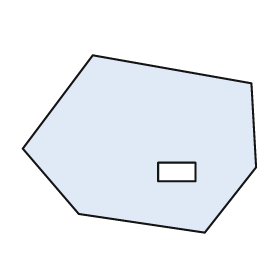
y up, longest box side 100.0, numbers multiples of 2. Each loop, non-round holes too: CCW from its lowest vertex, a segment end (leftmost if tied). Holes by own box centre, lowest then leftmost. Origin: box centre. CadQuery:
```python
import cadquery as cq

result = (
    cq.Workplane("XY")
    .moveTo(28.0, -38.0)
    .lineTo(50.0, -10.0)
    .lineTo(48.0, 26.0)
    .lineTo(-20.0, 38.0)
    .lineTo(-50.0, -2.0)
    .lineTo(-26.0, -30.0)
    .close()
    .moveTo(8.0, -16.0)
    .lineTo(24.0, -16.0)
    .lineTo(24.0, -8.0)
    .lineTo(8.0, -8.0)
    .close()
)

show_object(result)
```